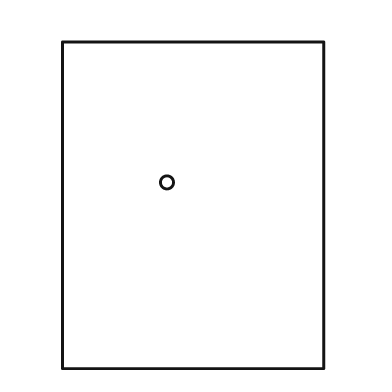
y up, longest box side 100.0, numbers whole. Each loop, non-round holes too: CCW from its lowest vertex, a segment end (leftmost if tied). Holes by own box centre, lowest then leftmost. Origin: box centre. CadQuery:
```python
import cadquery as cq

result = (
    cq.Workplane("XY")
    .moveTo(-40.0, -50.0)
    .lineTo(40.0, -50.0)
    .lineTo(40.0, 50.0)
    .lineTo(-40.0, 50.0)
    .close()
    .moveTo(-8.0, 7.0)
    .circle(2.0)
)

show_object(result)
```